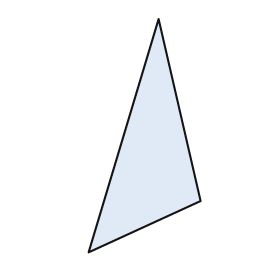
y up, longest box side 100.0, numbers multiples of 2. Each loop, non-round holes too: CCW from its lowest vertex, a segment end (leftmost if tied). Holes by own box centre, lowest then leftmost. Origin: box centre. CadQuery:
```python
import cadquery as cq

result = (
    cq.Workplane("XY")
    .moveTo(-24.0, -50.0)
    .lineTo(24.0, -28.0)
    .lineTo(6.0, 50.0)
    .close()
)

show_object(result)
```